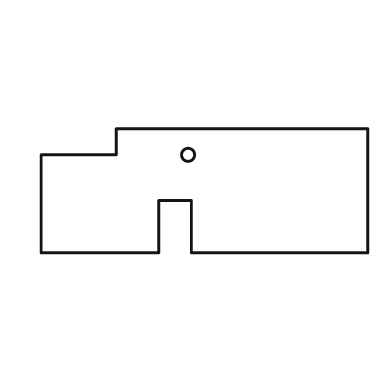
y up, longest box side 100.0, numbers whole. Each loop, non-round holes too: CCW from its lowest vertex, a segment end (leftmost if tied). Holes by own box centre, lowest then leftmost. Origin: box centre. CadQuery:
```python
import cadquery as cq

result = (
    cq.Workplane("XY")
    .moveTo(-50.0, -19.0)
    .lineTo(-14.0, -19.0)
    .lineTo(-14.0, -3.0)
    .lineTo(-4.0, -3.0)
    .lineTo(-4.0, -19.0)
    .lineTo(50.0, -19.0)
    .lineTo(50.0, 19.0)
    .lineTo(-27.0, 19.0)
    .lineTo(-27.0, 11.0)
    .lineTo(-50.0, 11.0)
    .close()
    .moveTo(-5.0, 11.0)
    .circle(2.0)
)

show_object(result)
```